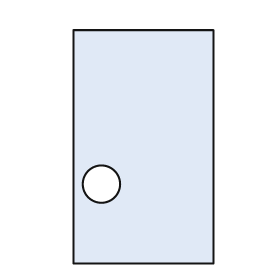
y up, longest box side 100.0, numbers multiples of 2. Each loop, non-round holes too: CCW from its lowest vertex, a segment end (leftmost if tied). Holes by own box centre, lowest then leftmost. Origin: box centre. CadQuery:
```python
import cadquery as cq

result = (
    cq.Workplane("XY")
    .moveTo(-30.0, -50.0)
    .lineTo(30.0, -50.0)
    .lineTo(30.0, 50.0)
    .lineTo(-30.0, 50.0)
    .close()
    .moveTo(-18.0, -16.0)
    .circle(8.0)
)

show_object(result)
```